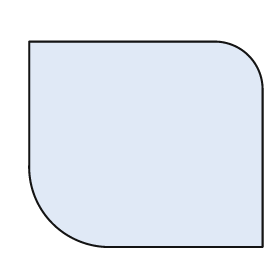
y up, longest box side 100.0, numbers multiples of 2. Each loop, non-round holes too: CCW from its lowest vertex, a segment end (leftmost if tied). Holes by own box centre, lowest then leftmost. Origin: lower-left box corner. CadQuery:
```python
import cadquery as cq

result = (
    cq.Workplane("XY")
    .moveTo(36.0, 0.0)
    .lineTo(100.0, 0.0)
    .lineTo(100.0, 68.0)
    .threePointArc((94.0, 82.0), (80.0, 88.0))
    .lineTo(0.0, 88.0)
    .lineTo(0.0, 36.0)
    .threePointArc((10.0, 10.0), (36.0, 0.0))
    .close()
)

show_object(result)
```